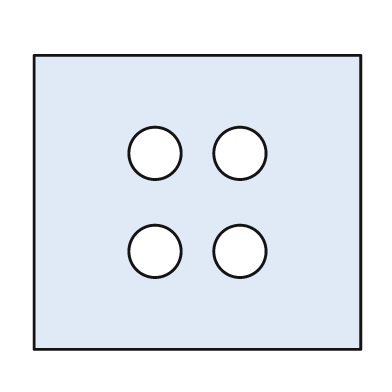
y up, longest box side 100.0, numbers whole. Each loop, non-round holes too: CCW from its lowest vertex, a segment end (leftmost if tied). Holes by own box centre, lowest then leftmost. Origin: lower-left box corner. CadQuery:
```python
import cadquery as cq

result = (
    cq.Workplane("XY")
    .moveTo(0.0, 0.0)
    .lineTo(100.0, 0.0)
    .lineTo(100.0, 90.0)
    .lineTo(0.0, 90.0)
    .close()
    .moveTo(37.0, 30.0)
    .circle(8.0)
    .moveTo(63.0, 30.0)
    .circle(8.0)
    .moveTo(37.0, 60.0)
    .circle(8.0)
    .moveTo(63.0, 60.0)
    .circle(8.0)
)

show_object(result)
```